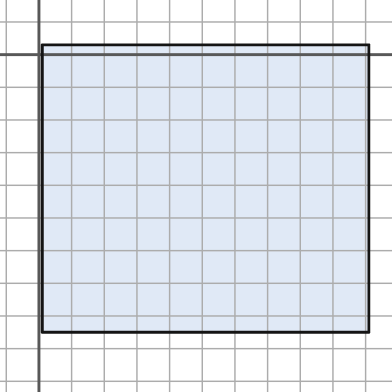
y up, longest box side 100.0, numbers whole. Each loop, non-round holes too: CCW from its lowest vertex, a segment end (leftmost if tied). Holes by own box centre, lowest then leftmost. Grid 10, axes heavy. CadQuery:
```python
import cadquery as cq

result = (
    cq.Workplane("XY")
    .moveTo(1.0, -85.0)
    .lineTo(101.0, -85.0)
    .lineTo(101.0, 3.0)
    .lineTo(1.0, 3.0)
    .close()
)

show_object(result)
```